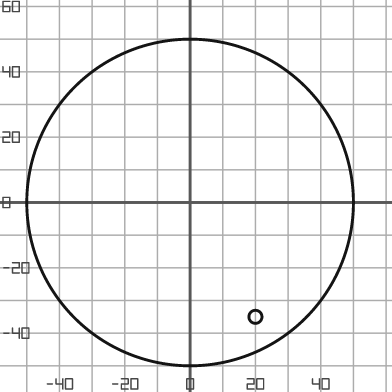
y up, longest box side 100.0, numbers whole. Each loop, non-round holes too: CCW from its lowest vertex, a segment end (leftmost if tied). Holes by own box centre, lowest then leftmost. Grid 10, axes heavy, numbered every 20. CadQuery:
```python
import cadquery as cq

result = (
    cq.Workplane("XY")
    .moveTo(0.0, 0.0)
    .circle(50.0)
    .moveTo(20.0, -35.0)
    .circle(2.0)
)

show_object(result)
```